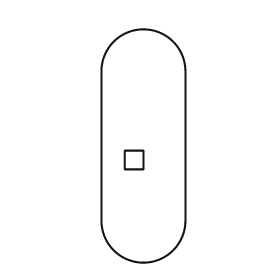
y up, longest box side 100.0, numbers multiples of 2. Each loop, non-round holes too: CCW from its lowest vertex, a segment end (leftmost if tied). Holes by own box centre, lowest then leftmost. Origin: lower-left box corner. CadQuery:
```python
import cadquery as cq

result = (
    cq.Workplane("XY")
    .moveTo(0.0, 18.0)
    .threePointArc((18.0, 0.0), (36.0, 18.0))
    .lineTo(36.0, 82.0)
    .threePointArc((18.0, 100.0), (0.0, 82.0))
    .close()
    .moveTo(10.0, 40.0)
    .lineTo(18.0, 40.0)
    .lineTo(18.0, 48.0)
    .lineTo(10.0, 48.0)
    .close()
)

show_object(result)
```